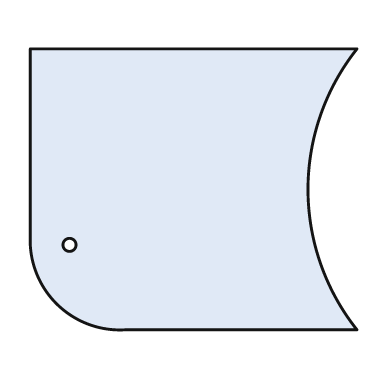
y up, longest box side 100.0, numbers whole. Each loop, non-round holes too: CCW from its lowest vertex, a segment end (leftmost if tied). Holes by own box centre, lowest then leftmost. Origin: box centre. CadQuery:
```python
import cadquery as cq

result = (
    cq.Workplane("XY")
    .moveTo(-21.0, -43.0)
    .lineTo(50.0, -43.0)
    .threePointArc((35.0, 0.0), (50.0, 43.0))
    .lineTo(-50.0, 43.0)
    .lineTo(-50.0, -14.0)
    .threePointArc((-42.0, -35.0), (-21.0, -43.0))
    .close()
    .moveTo(-38.0, -17.0)
    .circle(2.0)
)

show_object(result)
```